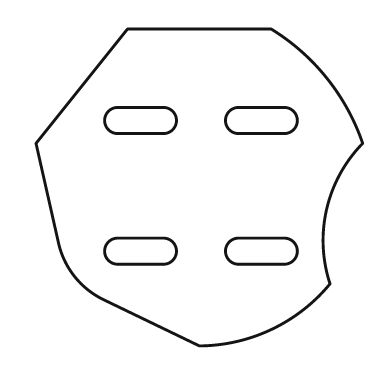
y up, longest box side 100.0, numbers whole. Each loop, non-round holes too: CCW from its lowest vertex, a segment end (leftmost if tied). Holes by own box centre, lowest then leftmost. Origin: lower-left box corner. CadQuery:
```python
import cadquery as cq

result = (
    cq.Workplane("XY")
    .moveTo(50.0, 0.0)
    .threePointArc((72.0, 5.0), (90.0, 19.0))
    .threePointArc((89.0, 42.0), (100.0, 62.0))
    .threePointArc((89.0, 82.0), (72.0, 97.0))
    .lineTo(28.0, 97.0)
    .lineTo(0.0, 62.0)
    .lineTo(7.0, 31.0)
    .threePointArc((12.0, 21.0), (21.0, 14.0))
    .close()
    .moveTo(25.0, 25.0)
    .lineTo(39.0, 25.0)
    .threePointArc((43.0, 29.0), (39.0, 33.0))
    .lineTo(25.0, 33.0)
    .threePointArc((21.0, 29.0), (25.0, 25.0))
    .close()
    .moveTo(62.0, 25.0)
    .lineTo(76.0, 25.0)
    .threePointArc((80.0, 29.0), (76.0, 33.0))
    .lineTo(62.0, 33.0)
    .threePointArc((58.0, 29.0), (62.0, 25.0))
    .close()
    .moveTo(25.0, 65.0)
    .lineTo(39.0, 65.0)
    .threePointArc((43.0, 69.0), (39.0, 73.0))
    .lineTo(25.0, 73.0)
    .threePointArc((21.0, 69.0), (25.0, 65.0))
    .close()
    .moveTo(62.0, 65.0)
    .lineTo(76.0, 65.0)
    .threePointArc((80.0, 69.0), (76.0, 73.0))
    .lineTo(62.0, 73.0)
    .threePointArc((58.0, 69.0), (62.0, 65.0))
    .close()
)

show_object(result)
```